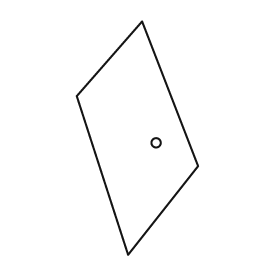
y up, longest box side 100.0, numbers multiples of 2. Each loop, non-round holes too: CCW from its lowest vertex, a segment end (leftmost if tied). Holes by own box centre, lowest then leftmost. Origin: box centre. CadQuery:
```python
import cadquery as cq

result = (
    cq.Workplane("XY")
    .moveTo(-4.0, -50.0)
    .lineTo(26.0, -12.0)
    .lineTo(2.0, 50.0)
    .lineTo(-26.0, 18.0)
    .close()
    .moveTo(8.0, -2.0)
    .circle(2.0)
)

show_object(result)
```